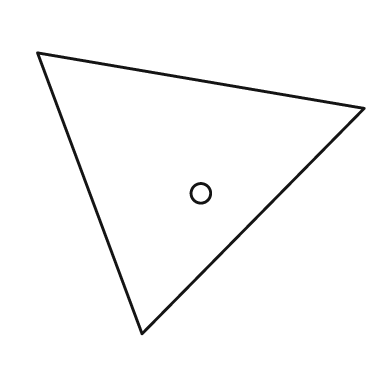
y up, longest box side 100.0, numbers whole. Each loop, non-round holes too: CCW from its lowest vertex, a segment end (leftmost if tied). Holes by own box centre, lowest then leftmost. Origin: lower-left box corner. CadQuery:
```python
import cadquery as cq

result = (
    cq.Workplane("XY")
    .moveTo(32.0, 0.0)
    .lineTo(100.0, 69.0)
    .lineTo(0.0, 86.0)
    .close()
    .moveTo(50.0, 43.0)
    .circle(3.0)
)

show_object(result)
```